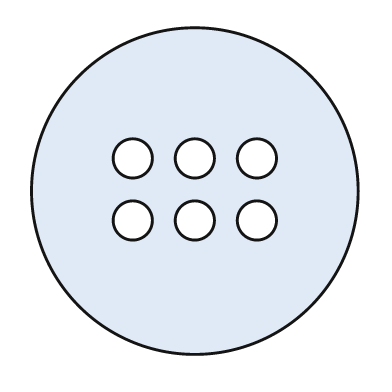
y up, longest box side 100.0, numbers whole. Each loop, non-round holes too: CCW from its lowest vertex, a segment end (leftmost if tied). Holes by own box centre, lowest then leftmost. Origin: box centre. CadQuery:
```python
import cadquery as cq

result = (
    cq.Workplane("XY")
    .moveTo(0.0, 0.0)
    .circle(50.0)
    .moveTo(-19.0, -9.0)
    .circle(6.0)
    .moveTo(0.0, -9.0)
    .circle(6.0)
    .moveTo(19.0, -9.0)
    .circle(6.0)
    .moveTo(-19.0, 10.0)
    .circle(6.0)
    .moveTo(0.0, 10.0)
    .circle(6.0)
    .moveTo(19.0, 10.0)
    .circle(6.0)
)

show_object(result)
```